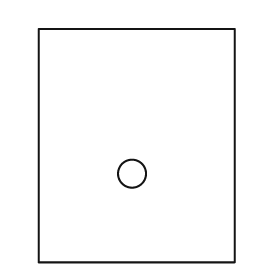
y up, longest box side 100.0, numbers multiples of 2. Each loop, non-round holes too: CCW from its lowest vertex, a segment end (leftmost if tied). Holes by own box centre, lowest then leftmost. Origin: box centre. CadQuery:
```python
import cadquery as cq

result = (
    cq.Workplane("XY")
    .moveTo(-42.0, -50.0)
    .lineTo(42.0, -50.0)
    .lineTo(42.0, 50.0)
    .lineTo(-42.0, 50.0)
    .close()
    .moveTo(-2.0, -12.0)
    .circle(6.0)
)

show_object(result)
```